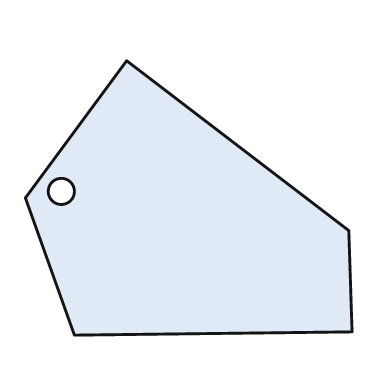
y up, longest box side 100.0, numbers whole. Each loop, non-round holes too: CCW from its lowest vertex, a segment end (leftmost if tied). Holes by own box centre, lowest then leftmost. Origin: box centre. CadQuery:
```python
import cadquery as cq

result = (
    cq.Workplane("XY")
    .moveTo(-35.0, -42.0)
    .lineTo(50.0, -41.0)
    .lineTo(49.0, -10.0)
    .lineTo(-19.0, 42.0)
    .lineTo(-50.0, 0.0)
    .close()
    .moveTo(-39.0, 2.0)
    .circle(4.0)
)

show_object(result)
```